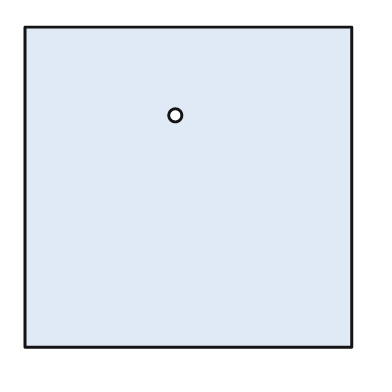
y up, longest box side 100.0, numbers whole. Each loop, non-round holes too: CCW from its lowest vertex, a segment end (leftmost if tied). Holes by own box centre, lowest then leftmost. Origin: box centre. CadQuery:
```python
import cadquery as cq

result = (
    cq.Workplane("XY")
    .moveTo(-50.0, -49.0)
    .lineTo(50.0, -49.0)
    .lineTo(50.0, 49.0)
    .lineTo(-50.0, 49.0)
    .close()
    .moveTo(-4.0, 22.0)
    .circle(2.0)
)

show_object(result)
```